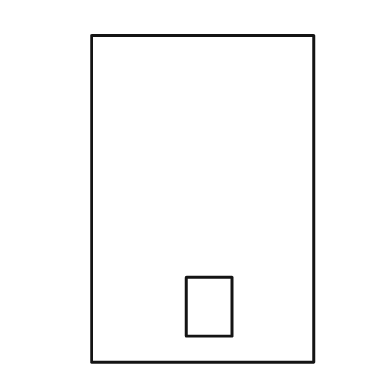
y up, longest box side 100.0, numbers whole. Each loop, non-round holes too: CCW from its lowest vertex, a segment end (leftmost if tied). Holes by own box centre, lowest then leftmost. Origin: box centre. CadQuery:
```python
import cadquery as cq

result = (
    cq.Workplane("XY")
    .moveTo(-34.0, -50.0)
    .lineTo(34.0, -50.0)
    .lineTo(34.0, 50.0)
    .lineTo(-34.0, 50.0)
    .close()
    .moveTo(-5.0, -42.0)
    .lineTo(9.0, -42.0)
    .lineTo(9.0, -24.0)
    .lineTo(-5.0, -24.0)
    .close()
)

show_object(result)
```